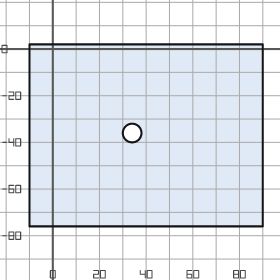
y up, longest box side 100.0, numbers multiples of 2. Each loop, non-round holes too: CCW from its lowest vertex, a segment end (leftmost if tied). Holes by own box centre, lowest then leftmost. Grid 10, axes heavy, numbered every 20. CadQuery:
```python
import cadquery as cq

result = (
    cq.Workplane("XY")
    .moveTo(-10.0, -76.0)
    .lineTo(90.0, -76.0)
    .lineTo(90.0, 2.0)
    .lineTo(-10.0, 2.0)
    .close()
    .moveTo(34.0, -36.0)
    .circle(4.0)
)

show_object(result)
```